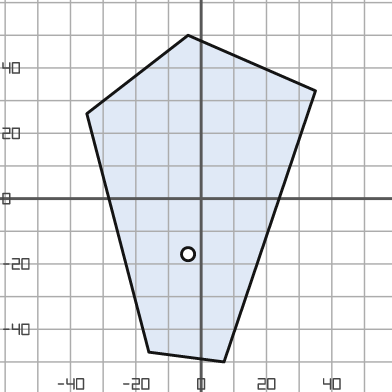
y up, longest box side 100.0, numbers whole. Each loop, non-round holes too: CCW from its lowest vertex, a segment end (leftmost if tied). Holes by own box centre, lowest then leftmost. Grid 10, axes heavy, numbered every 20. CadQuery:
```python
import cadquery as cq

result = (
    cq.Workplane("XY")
    .moveTo(7.0, -50.0)
    .lineTo(35.0, 33.0)
    .lineTo(-4.0, 50.0)
    .lineTo(-35.0, 26.0)
    .lineTo(-16.0, -47.0)
    .close()
    .moveTo(-4.0, -17.0)
    .circle(2.0)
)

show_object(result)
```